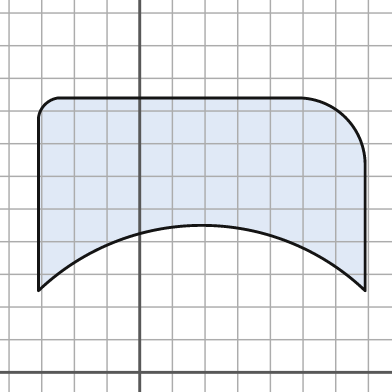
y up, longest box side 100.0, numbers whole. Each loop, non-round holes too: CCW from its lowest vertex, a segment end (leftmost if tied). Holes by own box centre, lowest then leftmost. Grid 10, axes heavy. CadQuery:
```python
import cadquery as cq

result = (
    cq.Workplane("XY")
    .moveTo(-31.0, 25.0)
    .threePointArc((19.0, 45.0), (69.0, 25.0))
    .lineTo(69.0, 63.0)
    .threePointArc((63.0, 78.0), (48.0, 84.0))
    .lineTo(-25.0, 84.0)
    .threePointArc((-29.0, 82.0), (-31.0, 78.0))
    .close()
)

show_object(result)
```